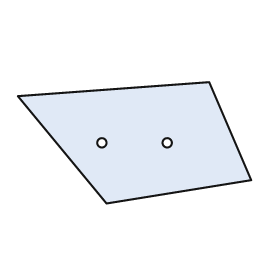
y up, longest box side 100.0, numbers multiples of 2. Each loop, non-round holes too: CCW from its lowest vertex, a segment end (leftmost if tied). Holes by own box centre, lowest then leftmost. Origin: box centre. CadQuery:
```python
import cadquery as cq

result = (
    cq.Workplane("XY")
    .moveTo(-12.0, -26.0)
    .lineTo(50.0, -16.0)
    .lineTo(32.0, 26.0)
    .lineTo(-50.0, 20.0)
    .close()
    .moveTo(-14.0, 0.0)
    .circle(2.0)
    .moveTo(14.0, 0.0)
    .circle(2.0)
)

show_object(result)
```